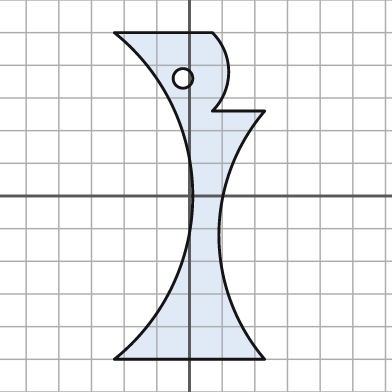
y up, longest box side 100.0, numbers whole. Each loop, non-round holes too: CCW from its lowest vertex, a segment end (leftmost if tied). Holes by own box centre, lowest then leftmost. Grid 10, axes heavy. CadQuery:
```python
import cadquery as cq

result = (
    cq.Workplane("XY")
    .moveTo(-23.0, -50.0)
    .lineTo(23.0, -50.0)
    .threePointArc((9.0, -12.0), (23.0, 26.0))
    .lineTo(7.0, 26.0)
    .threePointArc((12.0, 38.0), (7.0, 50.0))
    .lineTo(-23.0, 50.0)
    .threePointArc((1.0, 0.0), (-23.0, -50.0))
    .close()
    .moveTo(-2.0, 36.0)
    .circle(3.0)
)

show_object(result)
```